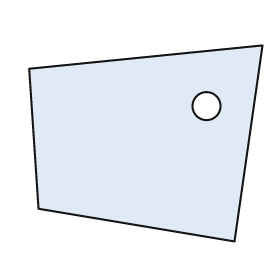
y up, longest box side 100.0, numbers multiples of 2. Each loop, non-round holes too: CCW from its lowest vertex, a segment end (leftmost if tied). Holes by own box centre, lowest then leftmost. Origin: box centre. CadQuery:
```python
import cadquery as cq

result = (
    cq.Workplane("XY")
    .moveTo(38.0, -42.0)
    .lineTo(50.0, 42.0)
    .lineTo(-50.0, 32.0)
    .lineTo(-46.0, -28.0)
    .close()
    .moveTo(26.0, 16.0)
    .circle(6.0)
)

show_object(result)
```